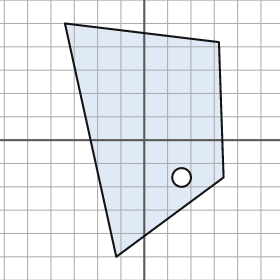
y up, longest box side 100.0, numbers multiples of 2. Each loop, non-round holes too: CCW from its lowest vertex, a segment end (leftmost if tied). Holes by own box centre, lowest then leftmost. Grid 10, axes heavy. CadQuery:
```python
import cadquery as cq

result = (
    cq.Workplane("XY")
    .moveTo(-12.0, -50.0)
    .lineTo(34.0, -16.0)
    .lineTo(32.0, 42.0)
    .lineTo(-34.0, 50.0)
    .close()
    .moveTo(16.0, -16.0)
    .circle(4.0)
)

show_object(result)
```